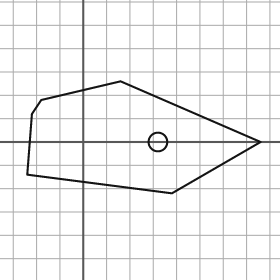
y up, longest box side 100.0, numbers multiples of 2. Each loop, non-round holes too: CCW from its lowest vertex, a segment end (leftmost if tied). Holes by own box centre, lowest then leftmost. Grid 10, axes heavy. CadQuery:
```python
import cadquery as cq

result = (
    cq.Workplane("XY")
    .moveTo(38.0, -22.0)
    .lineTo(76.0, 0.0)
    .lineTo(16.0, 26.0)
    .lineTo(-18.0, 18.0)
    .lineTo(-22.0, 12.0)
    .lineTo(-24.0, -14.0)
    .close()
    .moveTo(32.0, 0.0)
    .circle(4.0)
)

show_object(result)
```